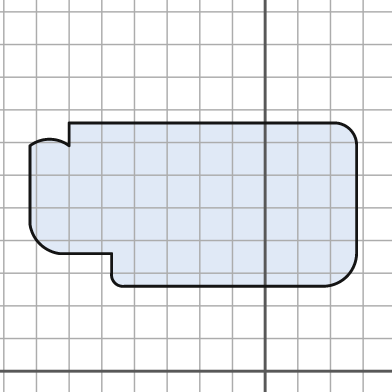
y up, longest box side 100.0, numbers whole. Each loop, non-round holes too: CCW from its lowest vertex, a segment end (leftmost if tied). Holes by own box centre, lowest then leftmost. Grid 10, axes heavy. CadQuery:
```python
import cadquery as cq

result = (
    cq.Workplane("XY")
    .moveTo(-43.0, 26.0)
    .lineTo(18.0, 26.0)
    .threePointArc((25.0, 29.0), (28.0, 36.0))
    .lineTo(28.0, 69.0)
    .threePointArc((26.0, 74.0), (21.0, 76.0))
    .lineTo(-60.0, 76.0)
    .lineTo(-60.0, 69.0)
    .threePointArc((-66.0, 71.0), (-72.0, 69.0))
    .lineTo(-72.0, 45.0)
    .threePointArc((-69.0, 39.0), (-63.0, 36.0))
    .lineTo(-47.0, 36.0)
    .lineTo(-47.0, 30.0)
    .threePointArc((-46.0, 27.0), (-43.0, 26.0))
    .close()
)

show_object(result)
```